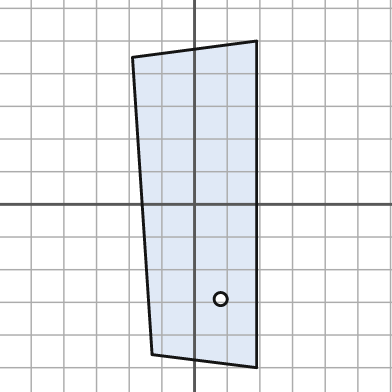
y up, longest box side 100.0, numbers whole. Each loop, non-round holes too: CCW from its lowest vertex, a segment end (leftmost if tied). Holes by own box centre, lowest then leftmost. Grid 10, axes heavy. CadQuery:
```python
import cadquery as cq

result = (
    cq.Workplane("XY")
    .moveTo(19.0, -50.0)
    .lineTo(19.0, 50.0)
    .lineTo(-19.0, 45.0)
    .lineTo(-13.0, -46.0)
    .close()
    .moveTo(8.0, -29.0)
    .circle(2.0)
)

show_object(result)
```